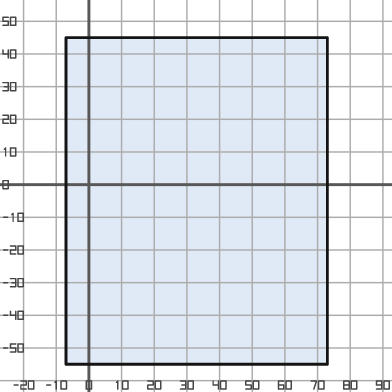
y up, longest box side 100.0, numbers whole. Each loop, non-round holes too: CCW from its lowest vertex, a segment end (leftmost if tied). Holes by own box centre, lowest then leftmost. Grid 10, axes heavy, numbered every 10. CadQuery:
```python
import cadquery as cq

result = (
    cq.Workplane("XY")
    .moveTo(-7.0, -55.0)
    .lineTo(73.0, -55.0)
    .lineTo(73.0, 45.0)
    .lineTo(-7.0, 45.0)
    .close()
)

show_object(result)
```